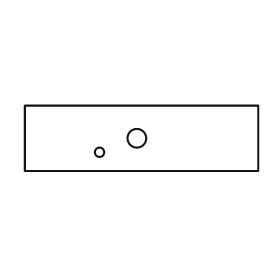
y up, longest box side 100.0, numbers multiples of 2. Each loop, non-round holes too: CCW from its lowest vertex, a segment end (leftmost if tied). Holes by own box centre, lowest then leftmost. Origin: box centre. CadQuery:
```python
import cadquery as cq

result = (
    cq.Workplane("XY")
    .moveTo(-50.0, -14.0)
    .lineTo(50.0, -14.0)
    .lineTo(50.0, 14.0)
    .lineTo(-50.0, 14.0)
    .close()
    .moveTo(-18.0, -6.0)
    .circle(2.0)
    .moveTo(-2.0, 0.0)
    .circle(4.0)
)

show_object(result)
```